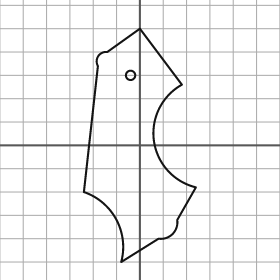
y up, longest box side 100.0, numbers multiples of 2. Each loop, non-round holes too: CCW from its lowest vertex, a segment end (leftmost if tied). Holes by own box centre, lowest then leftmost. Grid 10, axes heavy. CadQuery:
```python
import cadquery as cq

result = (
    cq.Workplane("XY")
    .moveTo(-8.0, -50.0)
    .lineTo(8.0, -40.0)
    .threePointArc((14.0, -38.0), (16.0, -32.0))
    .lineTo(24.0, -18.0)
    .threePointArc((6.0, 2.0), (18.0, 26.0))
    .lineTo(0.0, 50.0)
    .lineTo(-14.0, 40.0)
    .threePointArc((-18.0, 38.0), (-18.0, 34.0))
    .lineTo(-24.0, -20.0)
    .threePointArc((-10.0, -32.0), (-8.0, -50.0))
    .close()
    .moveTo(-4.0, 30.0)
    .circle(2.0)
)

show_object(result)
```